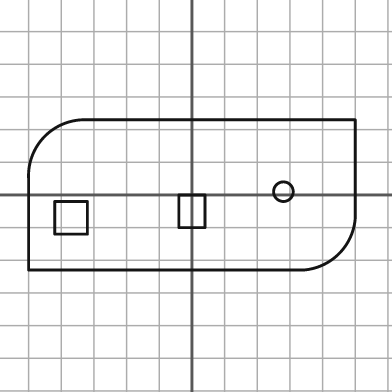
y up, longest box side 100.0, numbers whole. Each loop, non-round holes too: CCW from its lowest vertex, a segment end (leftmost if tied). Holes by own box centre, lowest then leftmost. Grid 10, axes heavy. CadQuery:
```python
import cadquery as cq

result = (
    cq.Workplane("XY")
    .moveTo(-50.0, -23.0)
    .lineTo(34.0, -23.0)
    .threePointArc((45.0, -18.0), (50.0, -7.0))
    .lineTo(50.0, 23.0)
    .lineTo(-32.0, 23.0)
    .threePointArc((-45.0, 18.0), (-50.0, 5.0))
    .close()
    .moveTo(-42.0, -12.0)
    .lineTo(-32.0, -12.0)
    .lineTo(-32.0, -2.0)
    .lineTo(-42.0, -2.0)
    .close()
    .moveTo(-4.0, -10.0)
    .lineTo(4.0, -10.0)
    .lineTo(4.0, 0.0)
    .lineTo(-4.0, 0.0)
    .close()
    .moveTo(28.0, 1.0)
    .circle(3.0)
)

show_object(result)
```